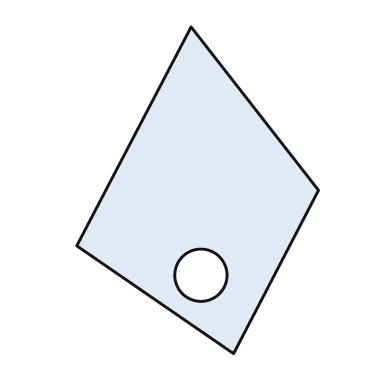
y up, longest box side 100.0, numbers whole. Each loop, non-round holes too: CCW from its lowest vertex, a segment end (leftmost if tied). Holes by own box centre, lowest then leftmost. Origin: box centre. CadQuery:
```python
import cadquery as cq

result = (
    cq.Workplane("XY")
    .moveTo(11.0, -50.0)
    .lineTo(37.0, 0.0)
    .lineTo(-2.0, 50.0)
    .lineTo(-37.0, -17.0)
    .close()
    .moveTo(1.0, -26.0)
    .circle(8.0)
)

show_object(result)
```